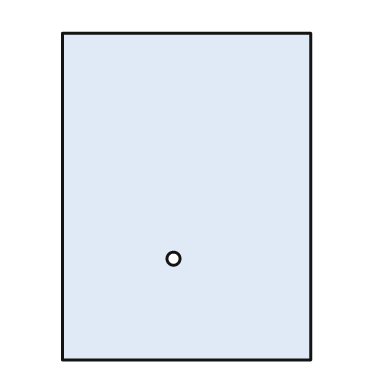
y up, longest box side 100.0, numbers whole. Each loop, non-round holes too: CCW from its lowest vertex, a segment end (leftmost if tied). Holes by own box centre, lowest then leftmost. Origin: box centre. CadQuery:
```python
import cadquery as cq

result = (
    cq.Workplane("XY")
    .moveTo(-38.0, -50.0)
    .lineTo(38.0, -50.0)
    .lineTo(38.0, 50.0)
    .lineTo(-38.0, 50.0)
    .close()
    .moveTo(-4.0, -19.0)
    .circle(2.0)
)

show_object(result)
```